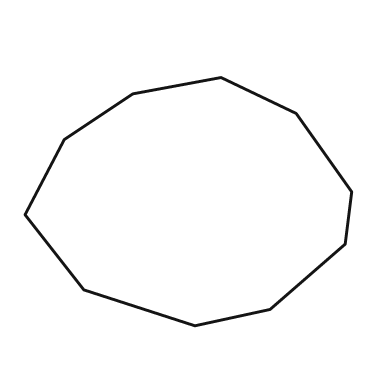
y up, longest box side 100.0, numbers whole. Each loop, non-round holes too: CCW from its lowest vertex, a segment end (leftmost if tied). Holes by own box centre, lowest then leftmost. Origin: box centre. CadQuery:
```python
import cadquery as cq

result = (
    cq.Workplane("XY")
    .moveTo(2.0, -38.0)
    .lineTo(25.0, -33.0)
    .lineTo(48.0, -13.0)
    .lineTo(50.0, 3.0)
    .lineTo(33.0, 27.0)
    .lineTo(10.0, 38.0)
    .lineTo(-17.0, 33.0)
    .lineTo(-38.0, 19.0)
    .lineTo(-50.0, -4.0)
    .lineTo(-32.0, -27.0)
    .close()
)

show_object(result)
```